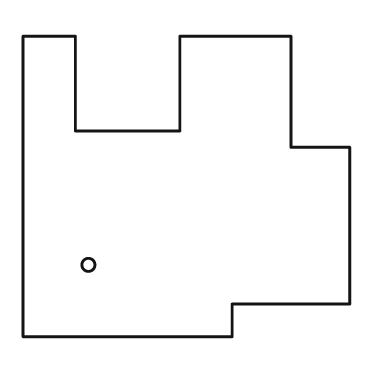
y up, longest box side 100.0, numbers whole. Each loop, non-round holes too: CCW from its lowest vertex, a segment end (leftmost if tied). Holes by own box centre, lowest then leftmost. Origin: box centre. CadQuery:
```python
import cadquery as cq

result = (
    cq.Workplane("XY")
    .moveTo(-50.0, -46.0)
    .lineTo(14.0, -46.0)
    .lineTo(14.0, -36.0)
    .lineTo(50.0, -36.0)
    .lineTo(50.0, 12.0)
    .lineTo(32.0, 12.0)
    .lineTo(32.0, 46.0)
    .lineTo(-2.0, 46.0)
    .lineTo(-2.0, 17.0)
    .lineTo(-34.0, 17.0)
    .lineTo(-34.0, 46.0)
    .lineTo(-50.0, 46.0)
    .close()
    .moveTo(-30.0, -24.0)
    .circle(2.0)
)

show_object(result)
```